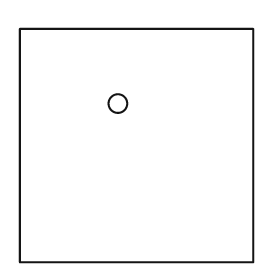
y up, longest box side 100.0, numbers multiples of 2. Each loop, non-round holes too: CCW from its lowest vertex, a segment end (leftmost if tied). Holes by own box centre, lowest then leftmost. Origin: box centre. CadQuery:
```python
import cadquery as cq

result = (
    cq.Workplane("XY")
    .moveTo(-50.0, -50.0)
    .lineTo(50.0, -50.0)
    .lineTo(50.0, 50.0)
    .lineTo(-50.0, 50.0)
    .close()
    .moveTo(-8.0, 18.0)
    .circle(4.0)
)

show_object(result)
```